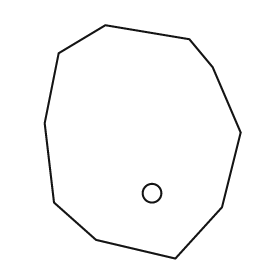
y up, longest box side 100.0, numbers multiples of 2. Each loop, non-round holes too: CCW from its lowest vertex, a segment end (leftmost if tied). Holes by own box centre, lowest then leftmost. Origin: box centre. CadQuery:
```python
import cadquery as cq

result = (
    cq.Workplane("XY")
    .moveTo(14.0, -50.0)
    .lineTo(34.0, -28.0)
    .lineTo(42.0, 4.0)
    .lineTo(30.0, 32.0)
    .lineTo(20.0, 44.0)
    .lineTo(-16.0, 50.0)
    .lineTo(-36.0, 38.0)
    .lineTo(-42.0, 8.0)
    .lineTo(-38.0, -26.0)
    .lineTo(-20.0, -42.0)
    .close()
    .moveTo(4.0, -22.0)
    .circle(4.0)
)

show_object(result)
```